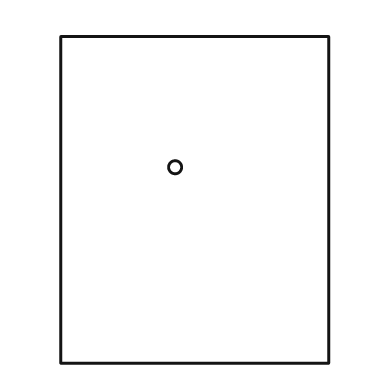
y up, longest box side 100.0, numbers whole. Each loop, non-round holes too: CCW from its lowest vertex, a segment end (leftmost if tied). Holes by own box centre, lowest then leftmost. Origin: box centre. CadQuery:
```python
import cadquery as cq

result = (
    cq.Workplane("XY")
    .moveTo(-41.0, -50.0)
    .lineTo(41.0, -50.0)
    .lineTo(41.0, 50.0)
    .lineTo(-41.0, 50.0)
    .close()
    .moveTo(-6.0, 10.0)
    .circle(2.0)
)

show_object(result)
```